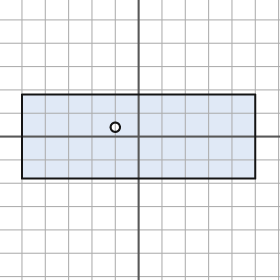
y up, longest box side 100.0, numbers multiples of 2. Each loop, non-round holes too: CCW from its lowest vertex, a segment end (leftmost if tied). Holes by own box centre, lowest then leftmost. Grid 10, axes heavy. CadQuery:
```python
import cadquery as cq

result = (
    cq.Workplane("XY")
    .moveTo(-50.0, -18.0)
    .lineTo(50.0, -18.0)
    .lineTo(50.0, 18.0)
    .lineTo(-50.0, 18.0)
    .close()
    .moveTo(-10.0, 4.0)
    .circle(2.0)
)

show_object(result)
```